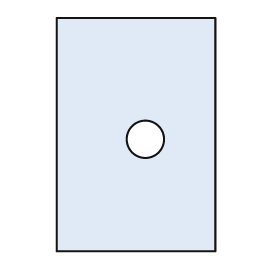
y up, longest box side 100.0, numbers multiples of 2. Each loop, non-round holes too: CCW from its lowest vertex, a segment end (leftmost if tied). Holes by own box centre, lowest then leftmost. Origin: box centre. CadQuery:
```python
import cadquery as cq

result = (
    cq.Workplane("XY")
    .moveTo(-34.0, -50.0)
    .lineTo(34.0, -50.0)
    .lineTo(34.0, 50.0)
    .lineTo(-34.0, 50.0)
    .close()
    .moveTo(4.0, -2.0)
    .circle(8.0)
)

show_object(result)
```